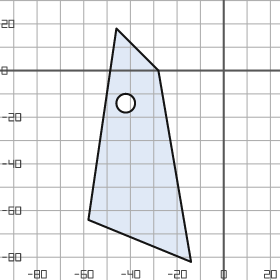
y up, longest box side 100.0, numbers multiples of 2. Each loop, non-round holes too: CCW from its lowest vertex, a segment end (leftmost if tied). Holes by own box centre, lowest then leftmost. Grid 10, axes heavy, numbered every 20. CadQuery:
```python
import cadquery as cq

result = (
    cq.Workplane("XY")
    .moveTo(-14.0, -82.0)
    .lineTo(-28.0, 0.0)
    .lineTo(-46.0, 18.0)
    .lineTo(-58.0, -64.0)
    .close()
    .moveTo(-42.0, -14.0)
    .circle(4.0)
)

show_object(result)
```